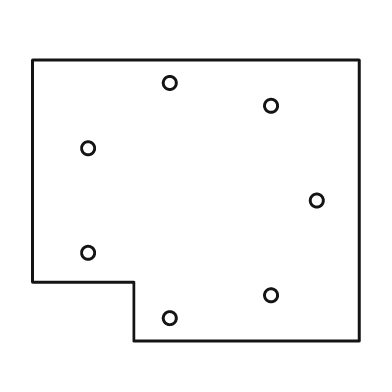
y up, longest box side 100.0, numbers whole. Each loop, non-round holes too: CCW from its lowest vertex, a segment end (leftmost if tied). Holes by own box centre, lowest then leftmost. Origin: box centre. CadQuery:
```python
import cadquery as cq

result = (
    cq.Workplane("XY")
    .moveTo(-19.0, -43.0)
    .lineTo(50.0, -43.0)
    .lineTo(50.0, 43.0)
    .lineTo(-50.0, 43.0)
    .lineTo(-50.0, -25.0)
    .lineTo(-19.0, -25.0)
    .close()
    .moveTo(-8.0, -36.0)
    .circle(2.0)
    .moveTo(23.0, -29.0)
    .circle(2.0)
    .moveTo(-33.0, -16.0)
    .circle(2.0)
    .moveTo(37.0, 0.0)
    .circle(2.0)
    .moveTo(-33.0, 16.0)
    .circle(2.0)
    .moveTo(23.0, 29.0)
    .circle(2.0)
    .moveTo(-8.0, 36.0)
    .circle(2.0)
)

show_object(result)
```